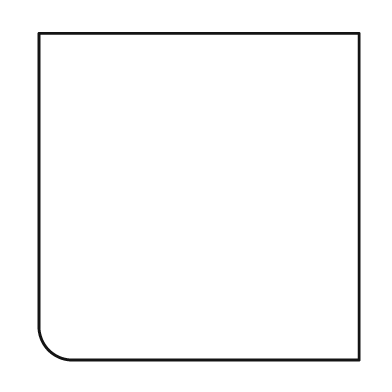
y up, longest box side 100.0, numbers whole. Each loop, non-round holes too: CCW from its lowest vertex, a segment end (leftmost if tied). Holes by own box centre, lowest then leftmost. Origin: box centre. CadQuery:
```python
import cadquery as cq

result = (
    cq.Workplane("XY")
    .moveTo(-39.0, -50.0)
    .lineTo(49.0, -50.0)
    .lineTo(49.0, 50.0)
    .lineTo(-49.0, 50.0)
    .lineTo(-49.0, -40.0)
    .threePointArc((-46.0, -47.0), (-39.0, -50.0))
    .close()
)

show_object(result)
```